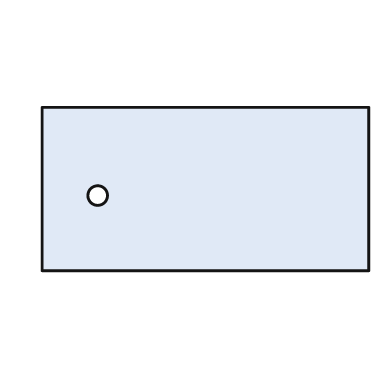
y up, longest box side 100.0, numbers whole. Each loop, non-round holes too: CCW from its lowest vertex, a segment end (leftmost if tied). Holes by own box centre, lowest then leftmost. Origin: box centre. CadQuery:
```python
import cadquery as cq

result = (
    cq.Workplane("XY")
    .moveTo(-50.0, -25.0)
    .lineTo(50.0, -25.0)
    .lineTo(50.0, 25.0)
    .lineTo(-50.0, 25.0)
    .close()
    .moveTo(-33.0, -2.0)
    .circle(3.0)
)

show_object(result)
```